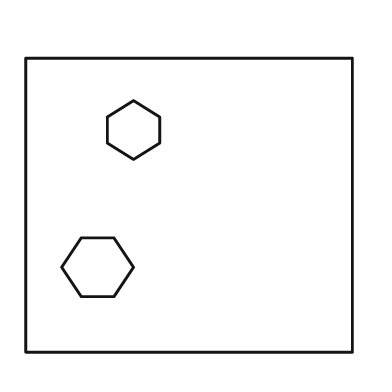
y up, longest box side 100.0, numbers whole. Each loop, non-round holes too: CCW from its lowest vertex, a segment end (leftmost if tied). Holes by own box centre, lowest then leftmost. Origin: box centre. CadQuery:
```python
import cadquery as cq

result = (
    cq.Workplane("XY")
    .moveTo(-50.0, -45.0)
    .lineTo(50.0, -45.0)
    .lineTo(50.0, 45.0)
    .lineTo(-50.0, 45.0)
    .close()
    .moveTo(-33.0, -28.0)
    .lineTo(-23.0, -28.0)
    .lineTo(-17.0, -19.0)
    .lineTo(-23.0, -10.0)
    .lineTo(-33.0, -10.0)
    .lineTo(-39.0, -19.0)
    .close()
    .moveTo(-17.0, 14.0)
    .lineTo(-9.0, 19.0)
    .lineTo(-9.0, 27.0)
    .lineTo(-17.0, 32.0)
    .lineTo(-25.0, 27.0)
    .lineTo(-25.0, 19.0)
    .close()
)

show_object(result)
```